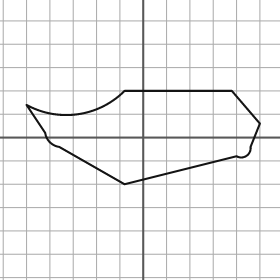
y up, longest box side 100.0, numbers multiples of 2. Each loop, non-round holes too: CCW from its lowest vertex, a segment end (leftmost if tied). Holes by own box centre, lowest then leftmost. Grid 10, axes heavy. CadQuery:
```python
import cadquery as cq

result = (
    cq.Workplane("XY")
    .moveTo(-8.0, -20.0)
    .lineTo(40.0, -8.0)
    .threePointArc((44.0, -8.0), (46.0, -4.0))
    .lineTo(50.0, 6.0)
    .lineTo(38.0, 20.0)
    .lineTo(-8.0, 20.0)
    .threePointArc((-28.0, 10.0), (-50.0, 14.0))
    .lineTo(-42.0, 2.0)
    .threePointArc((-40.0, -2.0), (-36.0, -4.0))
    .close()
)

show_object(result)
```